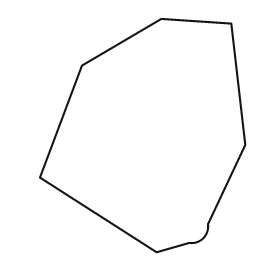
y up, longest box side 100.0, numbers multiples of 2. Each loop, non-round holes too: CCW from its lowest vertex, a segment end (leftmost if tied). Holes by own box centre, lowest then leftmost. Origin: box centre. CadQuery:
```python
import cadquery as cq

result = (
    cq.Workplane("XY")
    .moveTo(6.0, -50.0)
    .lineTo(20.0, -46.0)
    .threePointArc((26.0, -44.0), (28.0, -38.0))
    .lineTo(44.0, -4.0)
    .lineTo(38.0, 48.0)
    .lineTo(8.0, 50.0)
    .lineTo(-26.0, 30.0)
    .lineTo(-44.0, -18.0)
    .close()
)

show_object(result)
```